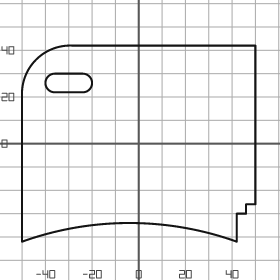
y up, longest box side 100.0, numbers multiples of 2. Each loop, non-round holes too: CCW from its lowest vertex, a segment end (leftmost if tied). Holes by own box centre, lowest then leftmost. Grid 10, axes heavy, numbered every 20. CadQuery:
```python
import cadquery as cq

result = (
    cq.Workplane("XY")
    .moveTo(-50.0, -42.0)
    .threePointArc((-4.0, -34.0), (42.0, -42.0))
    .lineTo(42.0, -30.0)
    .lineTo(46.0, -30.0)
    .lineTo(46.0, -26.0)
    .lineTo(50.0, -26.0)
    .lineTo(50.0, 42.0)
    .lineTo(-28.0, 42.0)
    .threePointArc((-44.0, 36.0), (-50.0, 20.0))
    .close()
    .moveTo(-36.0, 22.0)
    .lineTo(-24.0, 22.0)
    .threePointArc((-20.0, 26.0), (-24.0, 30.0))
    .lineTo(-36.0, 30.0)
    .threePointArc((-40.0, 26.0), (-36.0, 22.0))
    .close()
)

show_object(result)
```